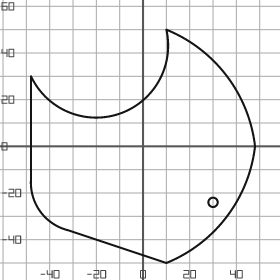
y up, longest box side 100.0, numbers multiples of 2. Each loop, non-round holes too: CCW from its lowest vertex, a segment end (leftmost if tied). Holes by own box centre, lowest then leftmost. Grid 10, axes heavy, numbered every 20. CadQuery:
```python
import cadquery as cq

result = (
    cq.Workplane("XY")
    .moveTo(10.0, -50.0)
    .threePointArc((36.0, -30.0), (48.0, 0.0))
    .threePointArc((36.0, 30.0), (10.0, 50.0))
    .threePointArc((-10.0, 14.0), (-48.0, 30.0))
    .lineTo(-48.0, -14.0)
    .threePointArc((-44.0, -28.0), (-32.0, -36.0))
    .close()
    .moveTo(30.0, -24.0)
    .circle(2.0)
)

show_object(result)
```